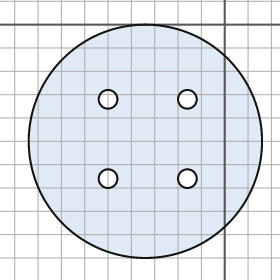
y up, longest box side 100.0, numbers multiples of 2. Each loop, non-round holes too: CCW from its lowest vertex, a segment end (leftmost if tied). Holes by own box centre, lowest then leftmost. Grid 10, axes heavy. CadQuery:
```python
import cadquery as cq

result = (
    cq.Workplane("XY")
    .moveTo(-34.0, -50.0)
    .circle(50.0)
    .moveTo(-50.0, -66.0)
    .circle(4.0)
    .moveTo(-16.0, -66.0)
    .circle(4.0)
    .moveTo(-50.0, -32.0)
    .circle(4.0)
    .moveTo(-16.0, -32.0)
    .circle(4.0)
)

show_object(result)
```